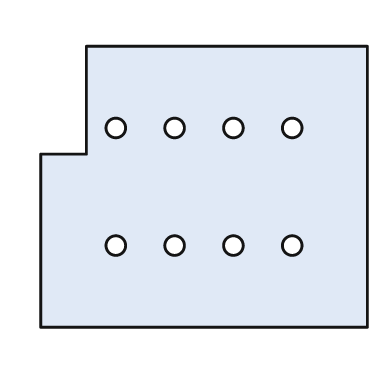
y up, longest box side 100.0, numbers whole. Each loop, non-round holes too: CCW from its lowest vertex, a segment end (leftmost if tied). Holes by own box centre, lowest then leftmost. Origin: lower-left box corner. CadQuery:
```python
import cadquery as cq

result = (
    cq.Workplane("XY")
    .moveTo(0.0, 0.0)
    .lineTo(100.0, 0.0)
    .lineTo(100.0, 86.0)
    .lineTo(14.0, 86.0)
    .lineTo(14.0, 53.0)
    .lineTo(0.0, 53.0)
    .close()
    .moveTo(23.0, 25.0)
    .circle(3.0)
    .moveTo(41.0, 25.0)
    .circle(3.0)
    .moveTo(59.0, 25.0)
    .circle(3.0)
    .moveTo(77.0, 25.0)
    .circle(3.0)
    .moveTo(23.0, 61.0)
    .circle(3.0)
    .moveTo(41.0, 61.0)
    .circle(3.0)
    .moveTo(59.0, 61.0)
    .circle(3.0)
    .moveTo(77.0, 61.0)
    .circle(3.0)
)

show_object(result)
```